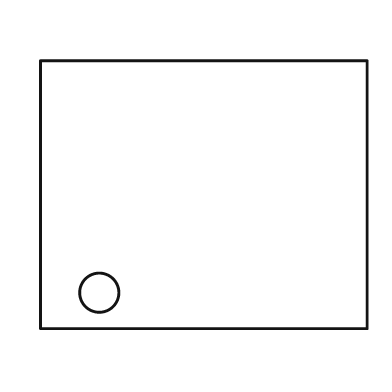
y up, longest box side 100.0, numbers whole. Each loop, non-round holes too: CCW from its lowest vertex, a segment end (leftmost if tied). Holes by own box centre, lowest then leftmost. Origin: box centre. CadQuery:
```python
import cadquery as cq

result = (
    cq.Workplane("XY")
    .moveTo(-50.0, -41.0)
    .lineTo(50.0, -41.0)
    .lineTo(50.0, 41.0)
    .lineTo(-50.0, 41.0)
    .close()
    .moveTo(-32.0, -30.0)
    .circle(6.0)
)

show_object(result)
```